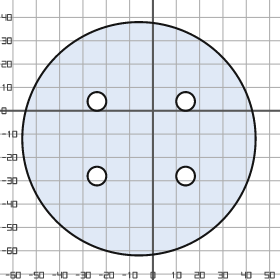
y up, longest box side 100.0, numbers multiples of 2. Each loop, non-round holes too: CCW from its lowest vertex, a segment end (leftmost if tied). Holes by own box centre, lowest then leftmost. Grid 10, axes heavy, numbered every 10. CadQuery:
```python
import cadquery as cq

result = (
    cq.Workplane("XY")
    .moveTo(-6.0, -12.0)
    .circle(50.0)
    .moveTo(-24.0, -28.0)
    .circle(4.0)
    .moveTo(14.0, -28.0)
    .circle(4.0)
    .moveTo(-24.0, 4.0)
    .circle(4.0)
    .moveTo(14.0, 4.0)
    .circle(4.0)
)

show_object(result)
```